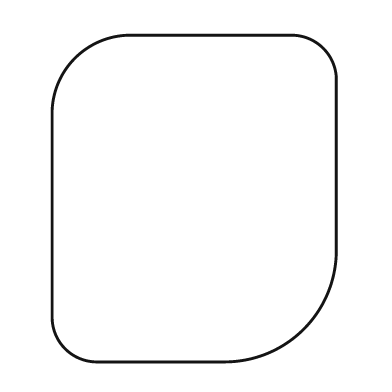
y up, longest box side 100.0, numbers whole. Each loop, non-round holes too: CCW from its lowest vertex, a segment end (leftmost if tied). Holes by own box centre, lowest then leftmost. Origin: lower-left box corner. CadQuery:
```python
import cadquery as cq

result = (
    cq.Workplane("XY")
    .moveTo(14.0, 0.0)
    .lineTo(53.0, 0.0)
    .threePointArc((77.0, 10.0), (87.0, 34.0))
    .lineTo(87.0, 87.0)
    .threePointArc((83.0, 96.0), (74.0, 100.0))
    .lineTo(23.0, 100.0)
    .threePointArc((7.0, 93.0), (0.0, 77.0))
    .lineTo(0.0, 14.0)
    .threePointArc((4.0, 4.0), (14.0, 0.0))
    .close()
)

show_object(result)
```